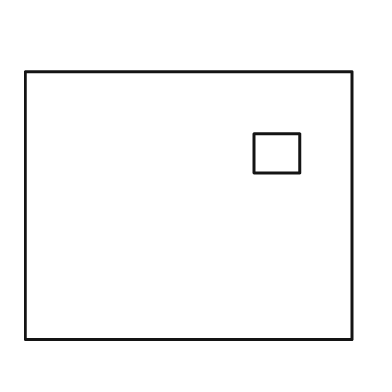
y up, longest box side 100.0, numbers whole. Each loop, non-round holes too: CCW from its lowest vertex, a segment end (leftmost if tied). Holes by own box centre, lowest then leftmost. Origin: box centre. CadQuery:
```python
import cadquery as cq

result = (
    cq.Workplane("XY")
    .moveTo(-50.0, -41.0)
    .lineTo(50.0, -41.0)
    .lineTo(50.0, 41.0)
    .lineTo(-50.0, 41.0)
    .close()
    .moveTo(20.0, 10.0)
    .lineTo(34.0, 10.0)
    .lineTo(34.0, 22.0)
    .lineTo(20.0, 22.0)
    .close()
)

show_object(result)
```